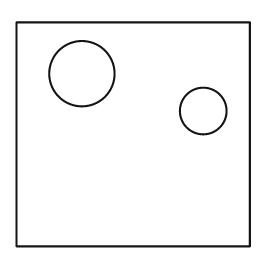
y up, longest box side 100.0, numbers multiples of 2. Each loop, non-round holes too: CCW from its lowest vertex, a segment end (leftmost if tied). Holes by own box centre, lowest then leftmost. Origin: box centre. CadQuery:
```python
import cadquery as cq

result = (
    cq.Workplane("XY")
    .moveTo(-50.0, -48.0)
    .lineTo(50.0, -48.0)
    .lineTo(50.0, 48.0)
    .lineTo(-50.0, 48.0)
    .close()
    .moveTo(30.0, 10.0)
    .circle(10.0)
    .moveTo(-22.0, 26.0)
    .circle(14.0)
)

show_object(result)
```